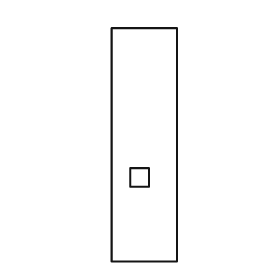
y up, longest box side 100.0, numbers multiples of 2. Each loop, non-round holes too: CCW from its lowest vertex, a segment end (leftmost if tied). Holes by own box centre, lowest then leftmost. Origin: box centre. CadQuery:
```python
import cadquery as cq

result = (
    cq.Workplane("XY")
    .moveTo(-14.0, -50.0)
    .lineTo(14.0, -50.0)
    .lineTo(14.0, 50.0)
    .lineTo(-14.0, 50.0)
    .close()
    .moveTo(-6.0, -18.0)
    .lineTo(2.0, -18.0)
    .lineTo(2.0, -10.0)
    .lineTo(-6.0, -10.0)
    .close()
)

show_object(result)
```